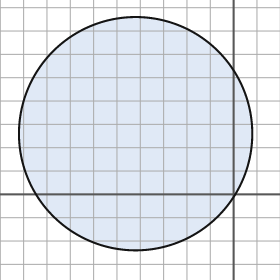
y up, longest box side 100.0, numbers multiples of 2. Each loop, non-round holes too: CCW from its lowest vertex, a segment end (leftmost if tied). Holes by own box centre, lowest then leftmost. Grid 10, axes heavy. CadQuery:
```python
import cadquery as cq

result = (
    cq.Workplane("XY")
    .moveTo(-42.0, 26.0)
    .circle(50.0)
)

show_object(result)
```